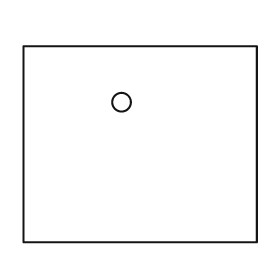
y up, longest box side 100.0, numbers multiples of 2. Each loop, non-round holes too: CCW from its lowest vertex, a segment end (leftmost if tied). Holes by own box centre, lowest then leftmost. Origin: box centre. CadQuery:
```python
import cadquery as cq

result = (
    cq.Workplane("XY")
    .moveTo(-50.0, -42.0)
    .lineTo(50.0, -42.0)
    .lineTo(50.0, 42.0)
    .lineTo(-50.0, 42.0)
    .close()
    .moveTo(-8.0, 18.0)
    .circle(4.0)
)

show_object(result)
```